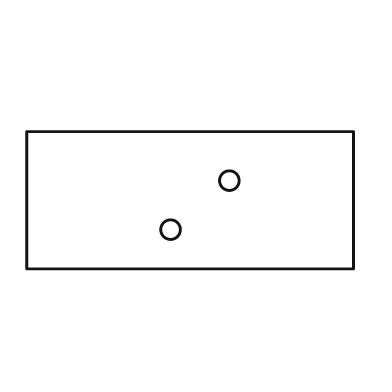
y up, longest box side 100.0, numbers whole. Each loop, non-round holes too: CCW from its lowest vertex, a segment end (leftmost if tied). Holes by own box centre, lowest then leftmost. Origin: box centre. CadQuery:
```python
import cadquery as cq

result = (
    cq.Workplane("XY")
    .moveTo(-50.0, -21.0)
    .lineTo(50.0, -21.0)
    .lineTo(50.0, 21.0)
    .lineTo(-50.0, 21.0)
    .close()
    .moveTo(-6.0, -9.0)
    .circle(3.0)
    .moveTo(12.0, 6.0)
    .circle(3.0)
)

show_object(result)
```